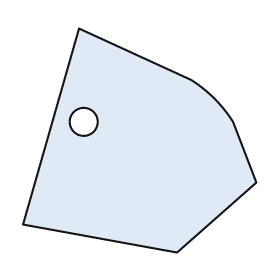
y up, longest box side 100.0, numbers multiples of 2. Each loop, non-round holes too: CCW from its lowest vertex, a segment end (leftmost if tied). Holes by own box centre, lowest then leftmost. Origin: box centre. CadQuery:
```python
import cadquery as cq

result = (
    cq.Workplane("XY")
    .moveTo(16.0, -48.0)
    .lineTo(50.0, -18.0)
    .lineTo(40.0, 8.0)
    .threePointArc((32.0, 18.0), (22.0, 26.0))
    .lineTo(-26.0, 48.0)
    .lineTo(-50.0, -36.0)
    .close()
    .moveTo(-24.0, 8.0)
    .circle(6.0)
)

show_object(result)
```